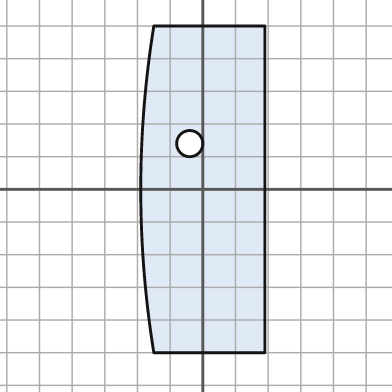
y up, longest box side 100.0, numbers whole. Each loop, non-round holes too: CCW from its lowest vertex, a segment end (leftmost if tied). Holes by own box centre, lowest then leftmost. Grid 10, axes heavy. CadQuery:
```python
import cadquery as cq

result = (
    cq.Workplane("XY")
    .moveTo(-15.0, -50.0)
    .lineTo(19.0, -50.0)
    .lineTo(19.0, 50.0)
    .lineTo(-15.0, 50.0)
    .threePointArc((-19.0, 0.0), (-15.0, -50.0))
    .close()
    .moveTo(-4.0, 14.0)
    .circle(4.0)
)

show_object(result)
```